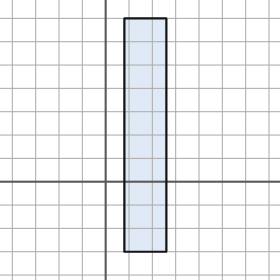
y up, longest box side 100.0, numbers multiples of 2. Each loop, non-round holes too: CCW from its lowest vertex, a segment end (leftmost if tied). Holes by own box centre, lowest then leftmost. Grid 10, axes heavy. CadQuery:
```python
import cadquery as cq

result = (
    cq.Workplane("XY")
    .moveTo(8.0, -30.0)
    .lineTo(26.0, -30.0)
    .lineTo(26.0, 70.0)
    .lineTo(8.0, 70.0)
    .close()
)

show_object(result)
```